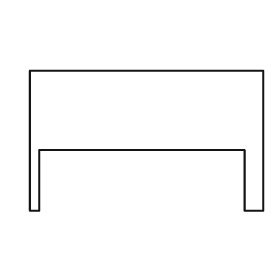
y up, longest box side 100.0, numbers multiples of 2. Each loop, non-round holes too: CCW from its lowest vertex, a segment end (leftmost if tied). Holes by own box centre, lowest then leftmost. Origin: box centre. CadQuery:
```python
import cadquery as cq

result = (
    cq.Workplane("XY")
    .moveTo(-50.0, -30.0)
    .lineTo(-46.0, -30.0)
    .lineTo(-46.0, -4.0)
    .lineTo(42.0, -4.0)
    .lineTo(42.0, -30.0)
    .lineTo(50.0, -30.0)
    .lineTo(50.0, 30.0)
    .lineTo(-50.0, 30.0)
    .close()
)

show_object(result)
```